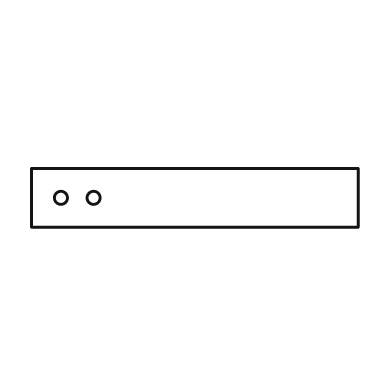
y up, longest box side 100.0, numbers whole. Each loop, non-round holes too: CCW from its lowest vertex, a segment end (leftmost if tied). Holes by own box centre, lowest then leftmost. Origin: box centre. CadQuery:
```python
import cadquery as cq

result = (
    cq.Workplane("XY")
    .moveTo(-50.0, -9.0)
    .lineTo(50.0, -9.0)
    .lineTo(50.0, 9.0)
    .lineTo(-50.0, 9.0)
    .close()
    .moveTo(-41.0, 0.0)
    .circle(2.0)
    .moveTo(-31.0, 0.0)
    .circle(2.0)
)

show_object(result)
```